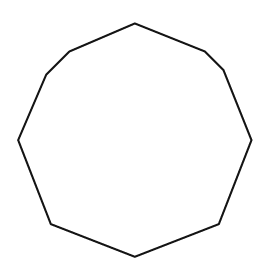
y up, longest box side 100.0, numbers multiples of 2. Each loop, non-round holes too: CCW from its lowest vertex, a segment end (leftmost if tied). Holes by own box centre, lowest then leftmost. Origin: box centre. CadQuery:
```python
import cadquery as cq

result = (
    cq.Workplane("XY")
    .moveTo(0.0, -50.0)
    .lineTo(36.0, -36.0)
    .lineTo(50.0, 0.0)
    .lineTo(38.0, 30.0)
    .lineTo(30.0, 38.0)
    .lineTo(0.0, 50.0)
    .lineTo(-28.0, 38.0)
    .lineTo(-38.0, 28.0)
    .lineTo(-50.0, 0.0)
    .lineTo(-36.0, -36.0)
    .close()
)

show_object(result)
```